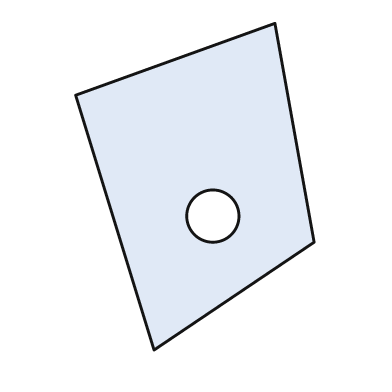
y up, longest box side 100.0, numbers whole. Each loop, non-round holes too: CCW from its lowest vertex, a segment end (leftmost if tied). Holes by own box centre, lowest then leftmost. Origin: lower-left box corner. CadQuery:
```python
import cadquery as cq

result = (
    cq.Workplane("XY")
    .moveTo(24.0, 0.0)
    .lineTo(73.0, 33.0)
    .lineTo(61.0, 100.0)
    .lineTo(0.0, 78.0)
    .close()
    .moveTo(42.0, 41.0)
    .circle(8.0)
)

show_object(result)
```